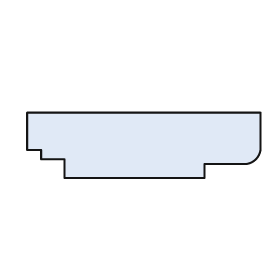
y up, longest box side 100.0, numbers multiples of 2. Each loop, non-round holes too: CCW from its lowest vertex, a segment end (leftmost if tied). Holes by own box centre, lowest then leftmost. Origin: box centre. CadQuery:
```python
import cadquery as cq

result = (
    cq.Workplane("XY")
    .moveTo(-34.0, -14.0)
    .lineTo(26.0, -14.0)
    .lineTo(26.0, -8.0)
    .lineTo(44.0, -8.0)
    .threePointArc((48.0, -6.0), (50.0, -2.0))
    .lineTo(50.0, 14.0)
    .lineTo(-50.0, 14.0)
    .lineTo(-50.0, -2.0)
    .lineTo(-44.0, -2.0)
    .lineTo(-44.0, -6.0)
    .lineTo(-34.0, -6.0)
    .close()
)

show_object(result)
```